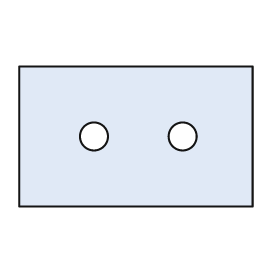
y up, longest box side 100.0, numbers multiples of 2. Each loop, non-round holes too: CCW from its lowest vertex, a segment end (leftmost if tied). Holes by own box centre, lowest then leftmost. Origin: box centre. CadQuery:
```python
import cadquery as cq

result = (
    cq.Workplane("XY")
    .moveTo(-50.0, -30.0)
    .lineTo(50.0, -30.0)
    .lineTo(50.0, 30.0)
    .lineTo(-50.0, 30.0)
    .close()
    .moveTo(-18.0, 0.0)
    .circle(6.0)
    .moveTo(20.0, 0.0)
    .circle(6.0)
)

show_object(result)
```